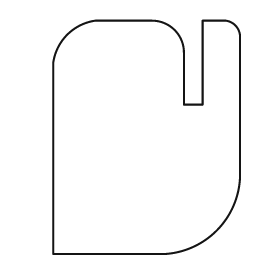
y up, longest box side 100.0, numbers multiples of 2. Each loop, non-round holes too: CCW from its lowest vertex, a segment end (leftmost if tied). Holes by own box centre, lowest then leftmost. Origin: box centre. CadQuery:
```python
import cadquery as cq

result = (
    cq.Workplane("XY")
    .moveTo(-40.0, -50.0)
    .lineTo(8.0, -50.0)
    .threePointArc((30.0, -40.0), (40.0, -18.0))
    .lineTo(40.0, 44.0)
    .threePointArc((38.0, 48.0), (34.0, 50.0))
    .lineTo(24.0, 50.0)
    .lineTo(24.0, 14.0)
    .lineTo(16.0, 14.0)
    .lineTo(16.0, 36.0)
    .threePointArc((12.0, 46.0), (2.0, 50.0))
    .lineTo(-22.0, 50.0)
    .threePointArc((-34.0, 44.0), (-40.0, 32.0))
    .close()
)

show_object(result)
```